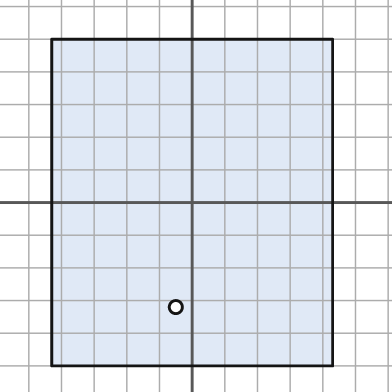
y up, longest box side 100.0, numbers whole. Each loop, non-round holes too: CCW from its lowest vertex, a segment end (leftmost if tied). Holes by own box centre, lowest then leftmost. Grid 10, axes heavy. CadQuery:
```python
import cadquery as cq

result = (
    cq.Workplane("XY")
    .moveTo(-43.0, -50.0)
    .lineTo(43.0, -50.0)
    .lineTo(43.0, 50.0)
    .lineTo(-43.0, 50.0)
    .close()
    .moveTo(-5.0, -32.0)
    .circle(2.0)
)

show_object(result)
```